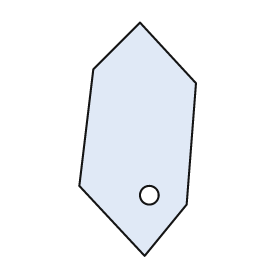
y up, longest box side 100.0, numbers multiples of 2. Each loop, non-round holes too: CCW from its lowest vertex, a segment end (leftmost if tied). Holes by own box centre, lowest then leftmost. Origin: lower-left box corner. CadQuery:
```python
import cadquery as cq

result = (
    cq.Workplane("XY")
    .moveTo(28.0, 0.0)
    .lineTo(46.0, 22.0)
    .lineTo(50.0, 74.0)
    .lineTo(26.0, 100.0)
    .lineTo(6.0, 80.0)
    .lineTo(0.0, 30.0)
    .close()
    .moveTo(30.0, 26.0)
    .circle(4.0)
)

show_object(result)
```